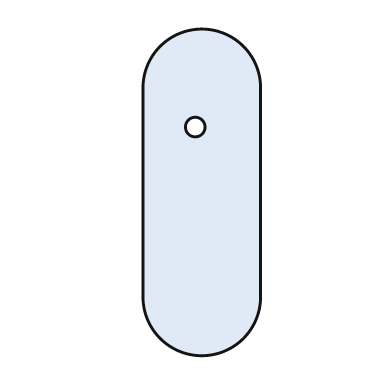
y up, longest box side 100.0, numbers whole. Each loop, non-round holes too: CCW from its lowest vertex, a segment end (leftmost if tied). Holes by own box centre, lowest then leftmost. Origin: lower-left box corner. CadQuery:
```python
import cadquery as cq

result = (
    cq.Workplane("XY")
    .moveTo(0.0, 18.0)
    .threePointArc((18.0, 0.0), (36.0, 18.0))
    .lineTo(36.0, 82.0)
    .threePointArc((18.0, 100.0), (0.0, 82.0))
    .close()
    .moveTo(16.0, 70.0)
    .circle(3.0)
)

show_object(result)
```